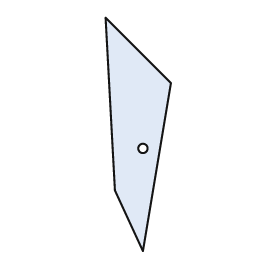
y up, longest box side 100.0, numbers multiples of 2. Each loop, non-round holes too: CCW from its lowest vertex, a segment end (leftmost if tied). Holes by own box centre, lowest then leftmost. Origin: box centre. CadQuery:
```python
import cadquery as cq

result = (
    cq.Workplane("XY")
    .moveTo(2.0, -50.0)
    .lineTo(14.0, 22.0)
    .lineTo(-14.0, 50.0)
    .lineTo(-10.0, -24.0)
    .close()
    .moveTo(2.0, -6.0)
    .circle(2.0)
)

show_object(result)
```